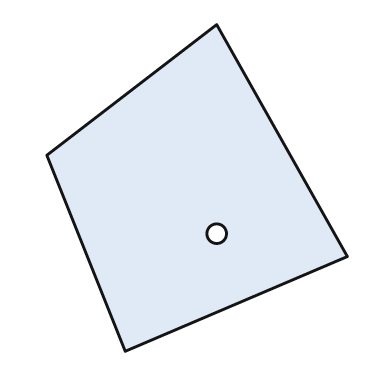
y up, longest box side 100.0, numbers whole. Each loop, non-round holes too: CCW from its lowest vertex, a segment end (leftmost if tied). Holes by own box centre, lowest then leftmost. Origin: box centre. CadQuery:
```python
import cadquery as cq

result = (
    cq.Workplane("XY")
    .moveTo(-22.0, -50.0)
    .lineTo(46.0, -21.0)
    .lineTo(6.0, 50.0)
    .lineTo(-46.0, 10.0)
    .close()
    .moveTo(6.0, -14.0)
    .circle(3.0)
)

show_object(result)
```